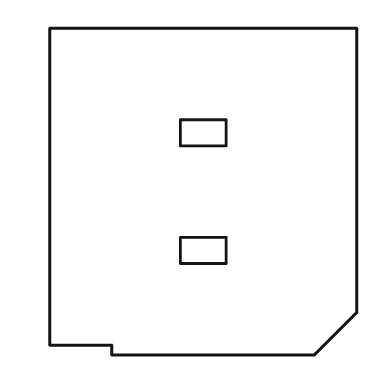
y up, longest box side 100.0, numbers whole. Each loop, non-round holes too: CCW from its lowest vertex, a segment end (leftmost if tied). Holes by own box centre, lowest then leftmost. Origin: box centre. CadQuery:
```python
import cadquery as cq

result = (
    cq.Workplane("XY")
    .moveTo(-28.0, -50.0)
    .lineTo(34.0, -50.0)
    .lineTo(47.0, -37.0)
    .lineTo(47.0, 50.0)
    .lineTo(-47.0, 50.0)
    .lineTo(-47.0, -47.0)
    .lineTo(-28.0, -47.0)
    .close()
    .moveTo(-7.0, -22.0)
    .lineTo(7.0, -22.0)
    .lineTo(7.0, -14.0)
    .lineTo(-7.0, -14.0)
    .close()
    .moveTo(-7.0, 14.0)
    .lineTo(7.0, 14.0)
    .lineTo(7.0, 22.0)
    .lineTo(-7.0, 22.0)
    .close()
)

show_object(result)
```